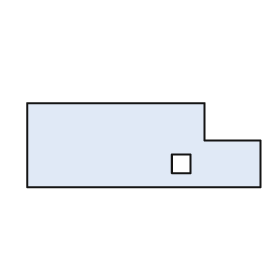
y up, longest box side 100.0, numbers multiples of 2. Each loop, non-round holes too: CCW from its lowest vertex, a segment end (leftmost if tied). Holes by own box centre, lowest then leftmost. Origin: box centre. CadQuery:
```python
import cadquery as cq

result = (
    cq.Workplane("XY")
    .moveTo(-50.0, -18.0)
    .lineTo(50.0, -18.0)
    .lineTo(50.0, 2.0)
    .lineTo(26.0, 2.0)
    .lineTo(26.0, 18.0)
    .lineTo(-50.0, 18.0)
    .close()
    .moveTo(12.0, -12.0)
    .lineTo(20.0, -12.0)
    .lineTo(20.0, -4.0)
    .lineTo(12.0, -4.0)
    .close()
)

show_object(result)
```